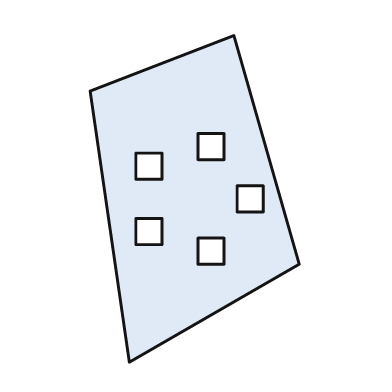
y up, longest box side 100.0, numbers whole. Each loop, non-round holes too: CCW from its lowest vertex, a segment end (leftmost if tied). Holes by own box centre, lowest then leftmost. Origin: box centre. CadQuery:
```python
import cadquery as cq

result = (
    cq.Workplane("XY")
    .moveTo(-20.0, -50.0)
    .lineTo(32.0, -20.0)
    .lineTo(12.0, 50.0)
    .lineTo(-32.0, 33.0)
    .close()
    .moveTo(1.0, -20.0)
    .lineTo(9.0, -20.0)
    .lineTo(9.0, -12.0)
    .lineTo(1.0, -12.0)
    .close()
    .moveTo(-18.0, -14.0)
    .lineTo(-10.0, -14.0)
    .lineTo(-10.0, -6.0)
    .lineTo(-18.0, -6.0)
    .close()
    .moveTo(13.0, -4.0)
    .lineTo(21.0, -4.0)
    .lineTo(21.0, 4.0)
    .lineTo(13.0, 4.0)
    .close()
    .moveTo(-18.0, 6.0)
    .lineTo(-10.0, 6.0)
    .lineTo(-10.0, 14.0)
    .lineTo(-18.0, 14.0)
    .close()
    .moveTo(1.0, 12.0)
    .lineTo(9.0, 12.0)
    .lineTo(9.0, 20.0)
    .lineTo(1.0, 20.0)
    .close()
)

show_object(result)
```